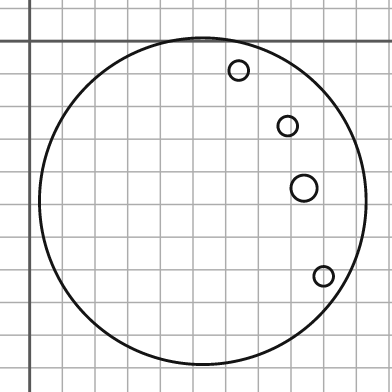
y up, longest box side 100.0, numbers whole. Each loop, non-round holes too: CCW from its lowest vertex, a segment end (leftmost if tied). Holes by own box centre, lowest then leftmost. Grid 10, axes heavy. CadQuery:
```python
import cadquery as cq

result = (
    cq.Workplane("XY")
    .moveTo(53.0, -49.0)
    .circle(50.0)
    .moveTo(90.0, -72.0)
    .circle(3.0)
    .moveTo(84.0, -45.0)
    .circle(4.0)
    .moveTo(79.0, -26.0)
    .circle(3.0)
    .moveTo(64.0, -9.0)
    .circle(3.0)
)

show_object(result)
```